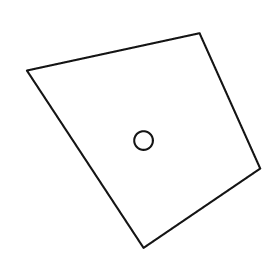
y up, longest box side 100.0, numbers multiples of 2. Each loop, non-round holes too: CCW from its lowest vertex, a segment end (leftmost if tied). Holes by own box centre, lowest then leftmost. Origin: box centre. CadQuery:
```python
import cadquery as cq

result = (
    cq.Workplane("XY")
    .moveTo(0.0, -46.0)
    .lineTo(50.0, -12.0)
    .lineTo(24.0, 46.0)
    .lineTo(-50.0, 30.0)
    .close()
    .moveTo(0.0, 0.0)
    .circle(4.0)
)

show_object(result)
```